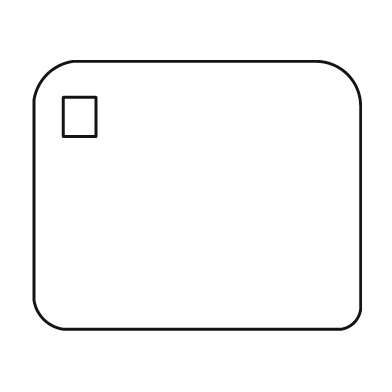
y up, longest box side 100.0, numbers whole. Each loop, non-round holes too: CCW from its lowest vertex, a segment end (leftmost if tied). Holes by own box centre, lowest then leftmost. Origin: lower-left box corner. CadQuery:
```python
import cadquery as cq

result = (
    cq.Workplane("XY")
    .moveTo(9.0, 0.0)
    .lineTo(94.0, 0.0)
    .threePointArc((98.0, 2.0), (100.0, 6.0))
    .lineTo(100.0, 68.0)
    .threePointArc((96.0, 78.0), (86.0, 82.0))
    .lineTo(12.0, 82.0)
    .threePointArc((4.0, 78.0), (0.0, 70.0))
    .lineTo(0.0, 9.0)
    .threePointArc((3.0, 3.0), (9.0, 0.0))
    .close()
    .moveTo(9.0, 59.0)
    .lineTo(19.0, 59.0)
    .lineTo(19.0, 71.0)
    .lineTo(9.0, 71.0)
    .close()
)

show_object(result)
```